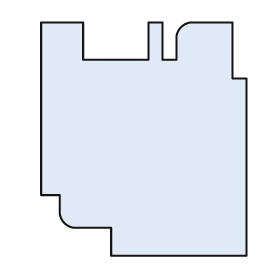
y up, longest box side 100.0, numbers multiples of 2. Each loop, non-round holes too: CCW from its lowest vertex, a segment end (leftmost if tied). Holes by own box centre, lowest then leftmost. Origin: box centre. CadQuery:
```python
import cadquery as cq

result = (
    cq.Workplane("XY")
    .moveTo(-14.0, -50.0)
    .lineTo(44.0, -50.0)
    .lineTo(44.0, 26.0)
    .lineTo(38.0, 26.0)
    .lineTo(38.0, 50.0)
    .lineTo(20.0, 50.0)
    .threePointArc((16.0, 48.0), (14.0, 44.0))
    .lineTo(14.0, 34.0)
    .lineTo(8.0, 34.0)
    .lineTo(8.0, 50.0)
    .lineTo(2.0, 50.0)
    .lineTo(2.0, 34.0)
    .lineTo(-26.0, 34.0)
    .lineTo(-26.0, 50.0)
    .lineTo(-44.0, 50.0)
    .lineTo(-44.0, -24.0)
    .lineTo(-36.0, -24.0)
    .lineTo(-36.0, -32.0)
    .threePointArc((-34.0, -36.0), (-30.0, -38.0))
    .lineTo(-14.0, -38.0)
    .close()
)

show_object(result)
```